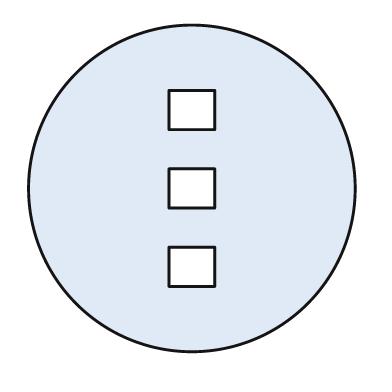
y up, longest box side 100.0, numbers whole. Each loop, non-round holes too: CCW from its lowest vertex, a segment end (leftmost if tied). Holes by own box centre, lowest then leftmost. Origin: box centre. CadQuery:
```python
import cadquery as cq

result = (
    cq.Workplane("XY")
    .moveTo(0.0, 0.0)
    .circle(50.0)
    .moveTo(-7.0, -30.0)
    .lineTo(7.0, -30.0)
    .lineTo(7.0, -18.0)
    .lineTo(-7.0, -18.0)
    .close()
    .moveTo(-7.0, -6.0)
    .lineTo(7.0, -6.0)
    .lineTo(7.0, 6.0)
    .lineTo(-7.0, 6.0)
    .close()
    .moveTo(-7.0, 18.0)
    .lineTo(7.0, 18.0)
    .lineTo(7.0, 30.0)
    .lineTo(-7.0, 30.0)
    .close()
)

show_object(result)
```